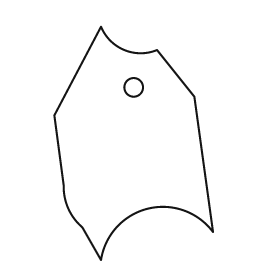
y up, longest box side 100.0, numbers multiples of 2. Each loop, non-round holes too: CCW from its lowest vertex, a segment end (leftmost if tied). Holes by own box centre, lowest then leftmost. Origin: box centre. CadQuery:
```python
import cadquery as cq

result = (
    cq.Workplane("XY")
    .moveTo(-14.0, -50.0)
    .threePointArc((6.0, -28.0), (34.0, -38.0))
    .lineTo(26.0, 20.0)
    .lineTo(10.0, 40.0)
    .threePointArc((-4.0, 40.0), (-14.0, 50.0))
    .lineTo(-34.0, 12.0)
    .lineTo(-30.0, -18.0)
    .threePointArc((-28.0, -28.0), (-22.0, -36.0))
    .close()
    .moveTo(0.0, 24.0)
    .circle(4.0)
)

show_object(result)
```